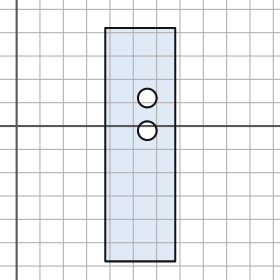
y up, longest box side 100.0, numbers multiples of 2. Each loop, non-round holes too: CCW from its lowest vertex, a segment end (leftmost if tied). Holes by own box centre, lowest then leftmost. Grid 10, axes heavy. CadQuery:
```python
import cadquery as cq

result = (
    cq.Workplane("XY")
    .moveTo(38.0, -58.0)
    .lineTo(68.0, -58.0)
    .lineTo(68.0, 42.0)
    .lineTo(38.0, 42.0)
    .close()
    .moveTo(56.0, -2.0)
    .circle(4.0)
    .moveTo(56.0, 12.0)
    .circle(4.0)
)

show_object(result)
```